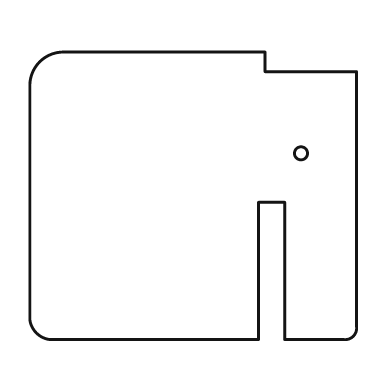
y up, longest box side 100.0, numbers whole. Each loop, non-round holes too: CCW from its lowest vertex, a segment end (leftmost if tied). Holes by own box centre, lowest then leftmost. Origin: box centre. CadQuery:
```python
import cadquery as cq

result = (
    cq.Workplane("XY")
    .moveTo(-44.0, -44.0)
    .lineTo(20.0, -44.0)
    .lineTo(20.0, -2.0)
    .lineTo(28.0, -2.0)
    .lineTo(28.0, -44.0)
    .lineTo(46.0, -44.0)
    .threePointArc((49.0, -43.0), (50.0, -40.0))
    .lineTo(50.0, 38.0)
    .lineTo(22.0, 38.0)
    .lineTo(22.0, 44.0)
    .lineTo(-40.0, 44.0)
    .threePointArc((-47.0, 41.0), (-50.0, 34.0))
    .lineTo(-50.0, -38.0)
    .threePointArc((-48.0, -42.0), (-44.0, -44.0))
    .close()
    .moveTo(33.0, 13.0)
    .circle(2.0)
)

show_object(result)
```